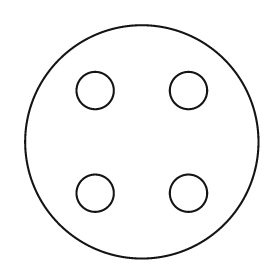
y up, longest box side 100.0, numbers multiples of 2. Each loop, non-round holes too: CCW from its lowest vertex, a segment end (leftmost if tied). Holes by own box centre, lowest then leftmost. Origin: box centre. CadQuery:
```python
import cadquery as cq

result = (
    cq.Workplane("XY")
    .moveTo(0.0, 0.0)
    .circle(50.0)
    .moveTo(-20.0, -22.0)
    .circle(8.0)
    .moveTo(20.0, -22.0)
    .circle(8.0)
    .moveTo(-20.0, 22.0)
    .circle(8.0)
    .moveTo(20.0, 22.0)
    .circle(8.0)
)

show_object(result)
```